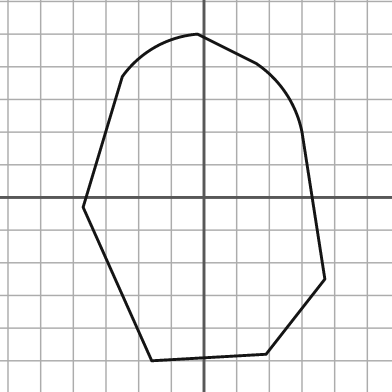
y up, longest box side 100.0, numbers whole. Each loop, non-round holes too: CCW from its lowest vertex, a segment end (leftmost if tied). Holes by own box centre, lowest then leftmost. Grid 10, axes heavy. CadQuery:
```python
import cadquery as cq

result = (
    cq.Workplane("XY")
    .moveTo(-16.0, -50.0)
    .lineTo(19.0, -48.0)
    .lineTo(37.0, -25.0)
    .lineTo(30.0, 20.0)
    .threePointArc((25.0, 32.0), (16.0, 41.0))
    .lineTo(-2.0, 50.0)
    .threePointArc((-15.0, 46.0), (-25.0, 37.0))
    .lineTo(-37.0, -3.0)
    .close()
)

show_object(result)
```